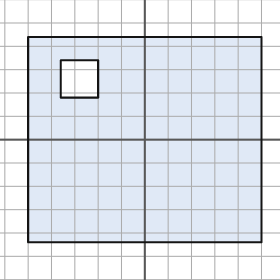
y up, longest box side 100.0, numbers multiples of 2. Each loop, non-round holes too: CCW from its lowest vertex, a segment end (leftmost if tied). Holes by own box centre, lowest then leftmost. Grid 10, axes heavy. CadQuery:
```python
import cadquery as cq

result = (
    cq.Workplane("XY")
    .moveTo(-50.0, -44.0)
    .lineTo(50.0, -44.0)
    .lineTo(50.0, 44.0)
    .lineTo(-50.0, 44.0)
    .close()
    .moveTo(-36.0, 18.0)
    .lineTo(-20.0, 18.0)
    .lineTo(-20.0, 34.0)
    .lineTo(-36.0, 34.0)
    .close()
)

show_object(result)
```